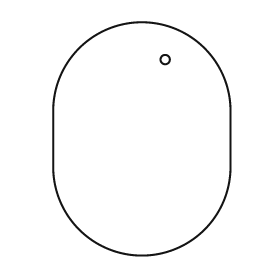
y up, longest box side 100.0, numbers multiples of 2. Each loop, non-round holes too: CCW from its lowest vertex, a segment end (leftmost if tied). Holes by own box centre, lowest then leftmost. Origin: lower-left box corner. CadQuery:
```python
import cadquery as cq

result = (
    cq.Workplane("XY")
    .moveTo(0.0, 38.0)
    .threePointArc((38.0, 0.0), (76.0, 38.0))
    .lineTo(76.0, 62.0)
    .threePointArc((38.0, 100.0), (0.0, 62.0))
    .close()
    .moveTo(48.0, 84.0)
    .circle(2.0)
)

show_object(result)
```